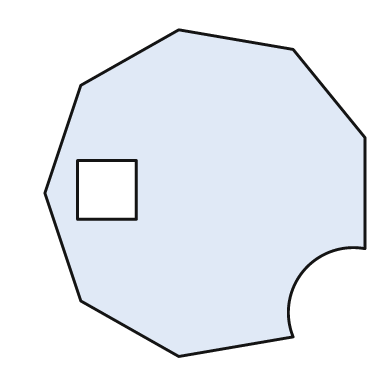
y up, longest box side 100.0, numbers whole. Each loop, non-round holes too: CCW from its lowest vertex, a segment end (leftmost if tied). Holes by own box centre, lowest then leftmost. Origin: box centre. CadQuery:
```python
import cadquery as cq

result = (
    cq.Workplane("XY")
    .moveTo(-8.0, -50.0)
    .lineTo(27.0, -44.0)
    .threePointArc((30.0, -24.0), (49.0, -17.0))
    .lineTo(49.0, 17.0)
    .lineTo(27.0, 44.0)
    .lineTo(-8.0, 50.0)
    .lineTo(-38.0, 33.0)
    .lineTo(-49.0, 0.0)
    .lineTo(-38.0, -33.0)
    .close()
    .moveTo(-39.0, -8.0)
    .lineTo(-21.0, -8.0)
    .lineTo(-21.0, 10.0)
    .lineTo(-39.0, 10.0)
    .close()
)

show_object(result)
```